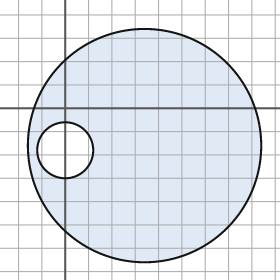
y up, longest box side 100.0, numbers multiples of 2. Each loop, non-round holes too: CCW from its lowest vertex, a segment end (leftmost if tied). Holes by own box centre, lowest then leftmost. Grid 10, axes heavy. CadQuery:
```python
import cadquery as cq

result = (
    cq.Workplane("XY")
    .moveTo(34.0, -16.0)
    .circle(50.0)
    .moveTo(0.0, -18.0)
    .circle(12.0)
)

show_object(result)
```